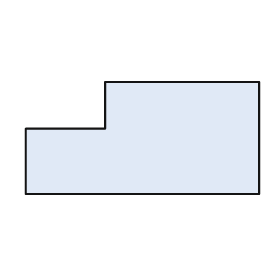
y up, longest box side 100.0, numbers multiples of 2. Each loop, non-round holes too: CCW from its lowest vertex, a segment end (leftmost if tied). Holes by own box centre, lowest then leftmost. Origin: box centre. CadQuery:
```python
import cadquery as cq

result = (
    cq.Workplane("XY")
    .moveTo(-50.0, -24.0)
    .lineTo(50.0, -24.0)
    .lineTo(50.0, 24.0)
    .lineTo(-16.0, 24.0)
    .lineTo(-16.0, 4.0)
    .lineTo(-50.0, 4.0)
    .close()
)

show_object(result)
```